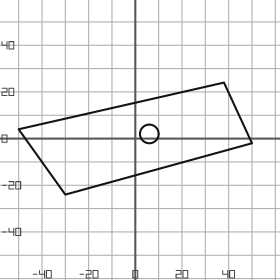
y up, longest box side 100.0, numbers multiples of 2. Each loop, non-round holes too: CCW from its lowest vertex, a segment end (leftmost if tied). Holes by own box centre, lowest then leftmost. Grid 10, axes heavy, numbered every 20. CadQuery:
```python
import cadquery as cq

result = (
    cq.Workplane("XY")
    .moveTo(-30.0, -24.0)
    .lineTo(50.0, -2.0)
    .lineTo(38.0, 24.0)
    .lineTo(-50.0, 4.0)
    .close()
    .moveTo(6.0, 2.0)
    .circle(4.0)
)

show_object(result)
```